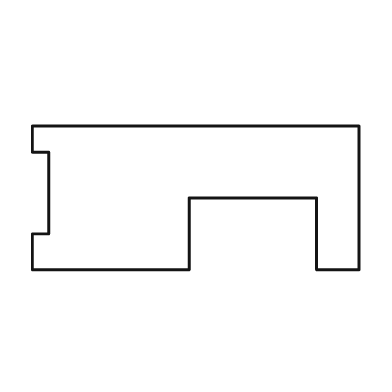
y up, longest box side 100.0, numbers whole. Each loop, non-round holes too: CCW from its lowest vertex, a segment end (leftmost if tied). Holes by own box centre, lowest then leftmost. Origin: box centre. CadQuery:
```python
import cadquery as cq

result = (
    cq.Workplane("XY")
    .moveTo(-50.0, -22.0)
    .lineTo(-2.0, -22.0)
    .lineTo(-2.0, 0.0)
    .lineTo(37.0, 0.0)
    .lineTo(37.0, -22.0)
    .lineTo(50.0, -22.0)
    .lineTo(50.0, 22.0)
    .lineTo(-50.0, 22.0)
    .lineTo(-50.0, 14.0)
    .lineTo(-45.0, 14.0)
    .lineTo(-45.0, -11.0)
    .lineTo(-50.0, -11.0)
    .close()
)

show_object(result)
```